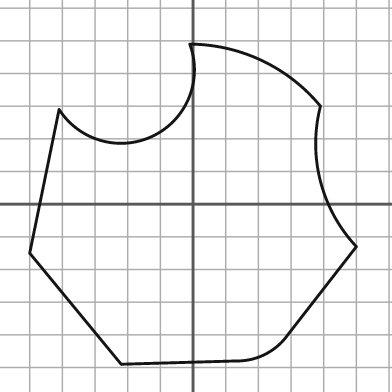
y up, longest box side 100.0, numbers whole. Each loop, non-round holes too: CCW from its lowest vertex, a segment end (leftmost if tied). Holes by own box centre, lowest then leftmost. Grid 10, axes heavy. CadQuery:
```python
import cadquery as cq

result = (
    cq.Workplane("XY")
    .moveTo(-22.0, -49.0)
    .lineTo(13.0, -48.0)
    .threePointArc((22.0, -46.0), (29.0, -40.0))
    .lineTo(50.0, -13.0)
    .threePointArc((39.0, 7.0), (39.0, 30.0))
    .threePointArc((21.0, 44.0), (-1.0, 49.0))
    .threePointArc((-12.0, 21.0), (-41.0, 29.0))
    .lineTo(-50.0, -15.0)
    .close()
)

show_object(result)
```